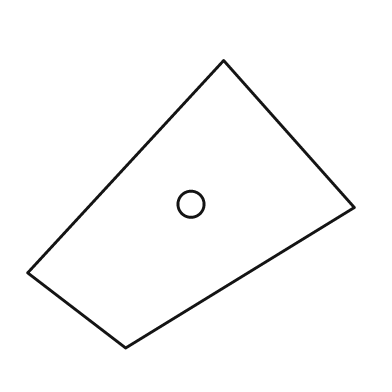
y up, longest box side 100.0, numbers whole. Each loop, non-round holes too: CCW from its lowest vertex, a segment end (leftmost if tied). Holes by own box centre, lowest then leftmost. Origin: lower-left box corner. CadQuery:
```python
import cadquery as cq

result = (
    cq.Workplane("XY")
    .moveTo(30.0, 0.0)
    .lineTo(100.0, 43.0)
    .lineTo(60.0, 88.0)
    .lineTo(0.0, 23.0)
    .close()
    .moveTo(50.0, 44.0)
    .circle(4.0)
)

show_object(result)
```